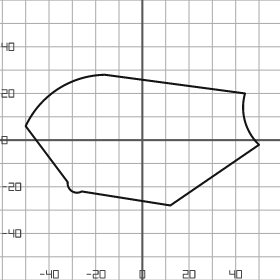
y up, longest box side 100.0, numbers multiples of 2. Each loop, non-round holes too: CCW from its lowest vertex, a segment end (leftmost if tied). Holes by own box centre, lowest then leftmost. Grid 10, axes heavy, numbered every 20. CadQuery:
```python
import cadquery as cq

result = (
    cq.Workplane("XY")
    .moveTo(12.0, -28.0)
    .lineTo(50.0, -2.0)
    .threePointArc((44.0, 8.0), (44.0, 20.0))
    .lineTo(-16.0, 28.0)
    .threePointArc((-36.0, 22.0), (-50.0, 6.0))
    .lineTo(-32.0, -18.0)
    .threePointArc((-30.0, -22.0), (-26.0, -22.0))
    .close()
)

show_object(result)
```